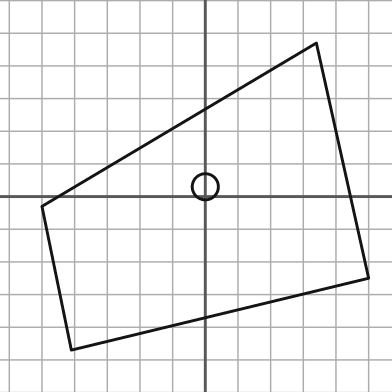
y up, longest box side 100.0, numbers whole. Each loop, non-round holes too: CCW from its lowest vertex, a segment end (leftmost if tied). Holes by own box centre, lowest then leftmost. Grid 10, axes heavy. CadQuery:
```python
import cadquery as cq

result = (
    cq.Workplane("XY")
    .moveTo(-41.0, -47.0)
    .lineTo(50.0, -25.0)
    .lineTo(34.0, 47.0)
    .lineTo(-50.0, -3.0)
    .close()
    .moveTo(0.0, 3.0)
    .circle(4.0)
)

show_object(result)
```